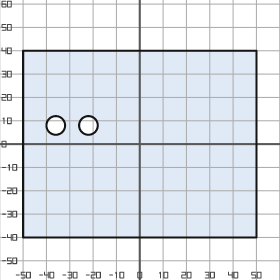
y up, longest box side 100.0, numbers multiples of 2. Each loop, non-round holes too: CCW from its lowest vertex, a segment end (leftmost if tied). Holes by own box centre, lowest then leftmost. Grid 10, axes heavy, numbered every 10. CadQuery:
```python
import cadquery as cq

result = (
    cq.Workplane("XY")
    .moveTo(-50.0, -40.0)
    .lineTo(50.0, -40.0)
    .lineTo(50.0, 40.0)
    .lineTo(-50.0, 40.0)
    .close()
    .moveTo(-36.0, 8.0)
    .circle(4.0)
    .moveTo(-22.0, 8.0)
    .circle(4.0)
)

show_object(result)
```